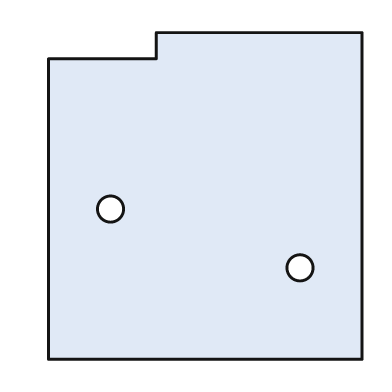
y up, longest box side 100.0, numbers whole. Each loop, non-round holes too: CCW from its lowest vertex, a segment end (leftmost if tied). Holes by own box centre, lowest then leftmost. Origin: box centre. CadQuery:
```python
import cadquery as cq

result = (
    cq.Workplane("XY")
    .moveTo(-48.0, -50.0)
    .lineTo(48.0, -50.0)
    .lineTo(48.0, 50.0)
    .lineTo(-15.0, 50.0)
    .lineTo(-15.0, 42.0)
    .lineTo(-48.0, 42.0)
    .close()
    .moveTo(29.0, -22.0)
    .circle(4.0)
    .moveTo(-29.0, -4.0)
    .circle(4.0)
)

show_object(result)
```